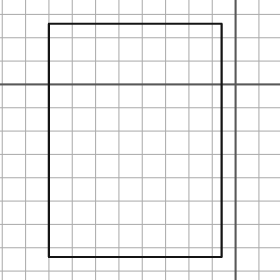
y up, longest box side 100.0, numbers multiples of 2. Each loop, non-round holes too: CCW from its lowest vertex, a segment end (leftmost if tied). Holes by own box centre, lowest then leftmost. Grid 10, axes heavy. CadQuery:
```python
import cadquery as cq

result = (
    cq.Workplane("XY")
    .moveTo(-80.0, -74.0)
    .lineTo(-6.0, -74.0)
    .lineTo(-6.0, 26.0)
    .lineTo(-80.0, 26.0)
    .close()
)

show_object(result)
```